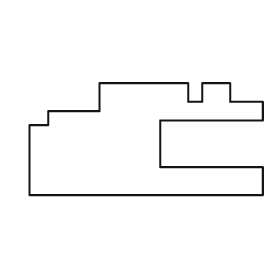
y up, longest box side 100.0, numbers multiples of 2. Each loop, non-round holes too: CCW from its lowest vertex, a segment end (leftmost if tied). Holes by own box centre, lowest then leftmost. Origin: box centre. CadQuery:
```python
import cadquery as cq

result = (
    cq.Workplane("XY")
    .moveTo(-50.0, -24.0)
    .lineTo(50.0, -24.0)
    .lineTo(50.0, -12.0)
    .lineTo(6.0, -12.0)
    .lineTo(6.0, 8.0)
    .lineTo(50.0, 8.0)
    .lineTo(50.0, 16.0)
    .lineTo(36.0, 16.0)
    .lineTo(36.0, 24.0)
    .lineTo(24.0, 24.0)
    .lineTo(24.0, 16.0)
    .lineTo(18.0, 16.0)
    .lineTo(18.0, 24.0)
    .lineTo(-20.0, 24.0)
    .lineTo(-20.0, 12.0)
    .lineTo(-42.0, 12.0)
    .lineTo(-42.0, 6.0)
    .lineTo(-50.0, 6.0)
    .close()
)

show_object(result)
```